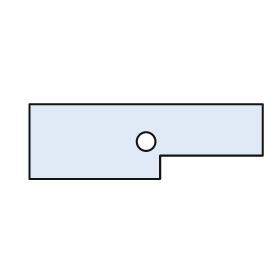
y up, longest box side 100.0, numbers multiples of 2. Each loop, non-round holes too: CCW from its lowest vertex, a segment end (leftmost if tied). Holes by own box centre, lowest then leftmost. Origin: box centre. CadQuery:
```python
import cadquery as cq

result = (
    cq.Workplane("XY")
    .moveTo(-50.0, -16.0)
    .lineTo(6.0, -16.0)
    .lineTo(6.0, -6.0)
    .lineTo(50.0, -6.0)
    .lineTo(50.0, 16.0)
    .lineTo(-50.0, 16.0)
    .close()
    .moveTo(0.0, 0.0)
    .circle(4.0)
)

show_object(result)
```